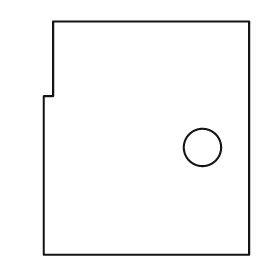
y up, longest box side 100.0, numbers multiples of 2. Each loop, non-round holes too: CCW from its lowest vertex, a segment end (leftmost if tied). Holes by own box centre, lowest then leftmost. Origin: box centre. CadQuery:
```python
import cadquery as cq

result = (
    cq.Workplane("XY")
    .moveTo(-44.0, -50.0)
    .lineTo(44.0, -50.0)
    .lineTo(44.0, 50.0)
    .lineTo(-40.0, 50.0)
    .lineTo(-40.0, 18.0)
    .lineTo(-44.0, 18.0)
    .close()
    .moveTo(24.0, -4.0)
    .circle(8.0)
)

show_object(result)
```